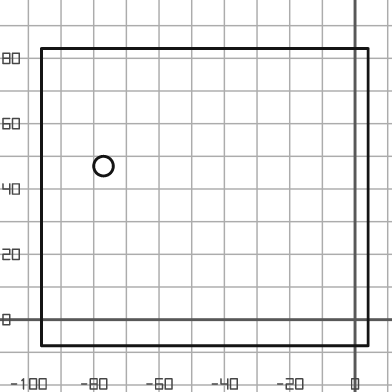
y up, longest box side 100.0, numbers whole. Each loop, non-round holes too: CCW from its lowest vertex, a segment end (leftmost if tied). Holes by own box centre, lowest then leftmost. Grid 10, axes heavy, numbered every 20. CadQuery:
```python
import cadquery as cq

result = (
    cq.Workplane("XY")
    .moveTo(-96.0, -8.0)
    .lineTo(4.0, -8.0)
    .lineTo(4.0, 83.0)
    .lineTo(-96.0, 83.0)
    .close()
    .moveTo(-77.0, 47.0)
    .circle(3.0)
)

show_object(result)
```